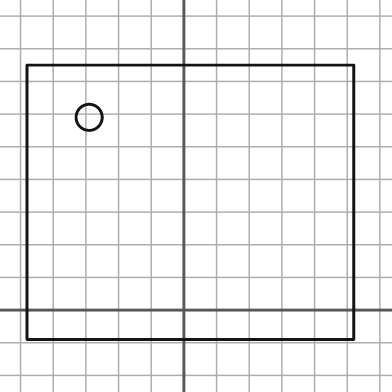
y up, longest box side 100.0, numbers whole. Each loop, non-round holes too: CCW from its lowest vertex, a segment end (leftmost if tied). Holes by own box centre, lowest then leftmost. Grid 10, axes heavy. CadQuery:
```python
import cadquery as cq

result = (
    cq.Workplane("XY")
    .moveTo(-48.0, -9.0)
    .lineTo(52.0, -9.0)
    .lineTo(52.0, 75.0)
    .lineTo(-48.0, 75.0)
    .close()
    .moveTo(-29.0, 59.0)
    .circle(4.0)
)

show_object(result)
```